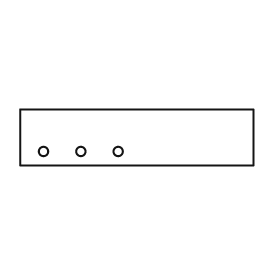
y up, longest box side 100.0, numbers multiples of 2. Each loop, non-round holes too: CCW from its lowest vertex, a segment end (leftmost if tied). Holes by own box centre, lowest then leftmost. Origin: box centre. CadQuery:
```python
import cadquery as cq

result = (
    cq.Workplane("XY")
    .moveTo(-50.0, -12.0)
    .lineTo(50.0, -12.0)
    .lineTo(50.0, 12.0)
    .lineTo(-50.0, 12.0)
    .close()
    .moveTo(-40.0, -6.0)
    .circle(2.0)
    .moveTo(-24.0, -6.0)
    .circle(2.0)
    .moveTo(-8.0, -6.0)
    .circle(2.0)
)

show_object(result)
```